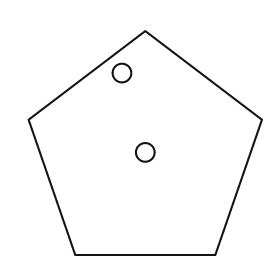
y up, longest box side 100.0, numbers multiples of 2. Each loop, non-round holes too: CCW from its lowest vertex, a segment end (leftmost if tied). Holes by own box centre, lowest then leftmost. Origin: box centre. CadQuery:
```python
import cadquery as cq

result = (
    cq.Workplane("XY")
    .moveTo(-30.0, -48.0)
    .lineTo(30.0, -48.0)
    .lineTo(50.0, 10.0)
    .lineTo(0.0, 48.0)
    .lineTo(-50.0, 10.0)
    .close()
    .moveTo(0.0, -4.0)
    .circle(4.0)
    .moveTo(-10.0, 30.0)
    .circle(4.0)
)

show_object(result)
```